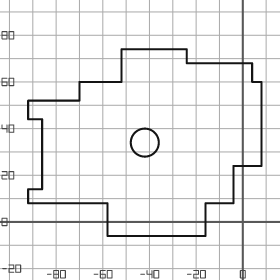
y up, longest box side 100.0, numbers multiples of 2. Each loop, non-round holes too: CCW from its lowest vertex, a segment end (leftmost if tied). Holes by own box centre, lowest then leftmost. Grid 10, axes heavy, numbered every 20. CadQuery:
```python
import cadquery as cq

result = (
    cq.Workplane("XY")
    .moveTo(-58.0, -6.0)
    .lineTo(-16.0, -6.0)
    .lineTo(-16.0, 8.0)
    .lineTo(-4.0, 8.0)
    .lineTo(-4.0, 24.0)
    .lineTo(8.0, 24.0)
    .lineTo(8.0, 60.0)
    .lineTo(4.0, 60.0)
    .lineTo(4.0, 68.0)
    .lineTo(-24.0, 68.0)
    .lineTo(-24.0, 74.0)
    .lineTo(-52.0, 74.0)
    .lineTo(-52.0, 60.0)
    .lineTo(-70.0, 60.0)
    .lineTo(-70.0, 52.0)
    .lineTo(-92.0, 52.0)
    .lineTo(-92.0, 44.0)
    .lineTo(-86.0, 44.0)
    .lineTo(-86.0, 14.0)
    .lineTo(-92.0, 14.0)
    .lineTo(-92.0, 8.0)
    .lineTo(-58.0, 8.0)
    .close()
    .moveTo(-42.0, 34.0)
    .circle(6.0)
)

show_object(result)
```